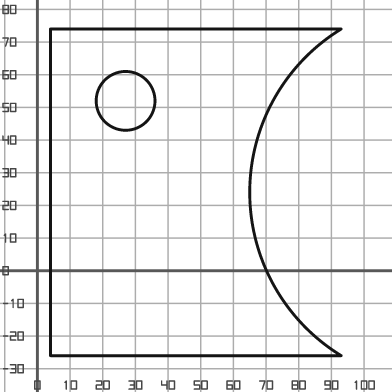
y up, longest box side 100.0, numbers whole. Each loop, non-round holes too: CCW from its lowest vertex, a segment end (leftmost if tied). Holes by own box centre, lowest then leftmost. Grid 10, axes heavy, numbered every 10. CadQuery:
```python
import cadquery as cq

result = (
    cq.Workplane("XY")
    .moveTo(4.0, -26.0)
    .lineTo(93.0, -26.0)
    .threePointArc((65.0, 24.0), (93.0, 74.0))
    .lineTo(4.0, 74.0)
    .close()
    .moveTo(27.0, 52.0)
    .circle(9.0)
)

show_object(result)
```